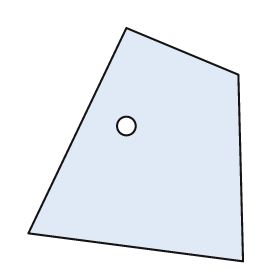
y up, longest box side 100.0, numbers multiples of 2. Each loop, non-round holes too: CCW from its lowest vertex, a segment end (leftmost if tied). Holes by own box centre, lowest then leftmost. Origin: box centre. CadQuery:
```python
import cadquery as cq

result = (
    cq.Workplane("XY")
    .moveTo(46.0, -50.0)
    .lineTo(44.0, 30.0)
    .lineTo(-4.0, 50.0)
    .lineTo(-46.0, -38.0)
    .close()
    .moveTo(-4.0, 8.0)
    .circle(4.0)
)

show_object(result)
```